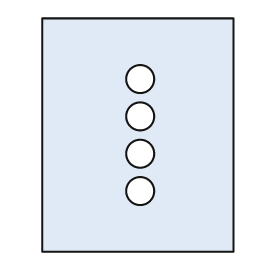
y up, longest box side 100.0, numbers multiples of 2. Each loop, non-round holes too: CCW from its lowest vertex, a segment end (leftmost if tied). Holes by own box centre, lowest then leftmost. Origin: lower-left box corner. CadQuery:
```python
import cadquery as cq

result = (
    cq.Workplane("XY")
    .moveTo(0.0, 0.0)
    .lineTo(82.0, 0.0)
    .lineTo(82.0, 100.0)
    .lineTo(0.0, 100.0)
    .close()
    .moveTo(42.0, 26.0)
    .circle(6.0)
    .moveTo(42.0, 42.0)
    .circle(6.0)
    .moveTo(42.0, 58.0)
    .circle(6.0)
    .moveTo(42.0, 74.0)
    .circle(6.0)
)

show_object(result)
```